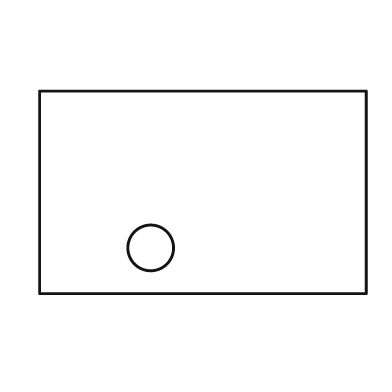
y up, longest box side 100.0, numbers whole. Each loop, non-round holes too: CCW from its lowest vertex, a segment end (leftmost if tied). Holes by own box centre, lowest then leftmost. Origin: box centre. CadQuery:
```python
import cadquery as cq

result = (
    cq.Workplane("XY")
    .moveTo(-50.0, -31.0)
    .lineTo(50.0, -31.0)
    .lineTo(50.0, 31.0)
    .lineTo(-50.0, 31.0)
    .close()
    .moveTo(-16.0, -17.0)
    .circle(7.0)
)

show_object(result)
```